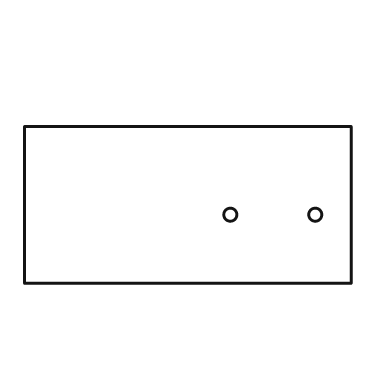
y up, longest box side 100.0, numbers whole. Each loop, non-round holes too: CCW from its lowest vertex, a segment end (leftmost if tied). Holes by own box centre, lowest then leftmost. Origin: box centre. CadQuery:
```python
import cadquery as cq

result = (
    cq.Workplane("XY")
    .moveTo(-50.0, -24.0)
    .lineTo(50.0, -24.0)
    .lineTo(50.0, 24.0)
    .lineTo(-50.0, 24.0)
    .close()
    .moveTo(13.0, -3.0)
    .circle(2.0)
    .moveTo(39.0, -3.0)
    .circle(2.0)
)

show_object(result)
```